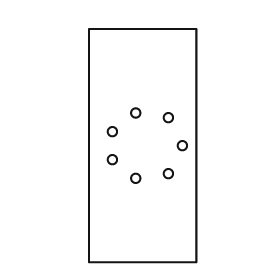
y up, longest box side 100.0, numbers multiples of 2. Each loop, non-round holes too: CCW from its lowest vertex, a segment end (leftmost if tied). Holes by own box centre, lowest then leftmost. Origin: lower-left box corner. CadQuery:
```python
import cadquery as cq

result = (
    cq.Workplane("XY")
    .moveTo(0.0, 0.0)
    .lineTo(46.0, 0.0)
    .lineTo(46.0, 100.0)
    .lineTo(0.0, 100.0)
    .close()
    .moveTo(20.0, 36.0)
    .circle(2.0)
    .moveTo(34.0, 38.0)
    .circle(2.0)
    .moveTo(10.0, 44.0)
    .circle(2.0)
    .moveTo(40.0, 50.0)
    .circle(2.0)
    .moveTo(10.0, 56.0)
    .circle(2.0)
    .moveTo(34.0, 62.0)
    .circle(2.0)
    .moveTo(20.0, 64.0)
    .circle(2.0)
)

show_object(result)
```